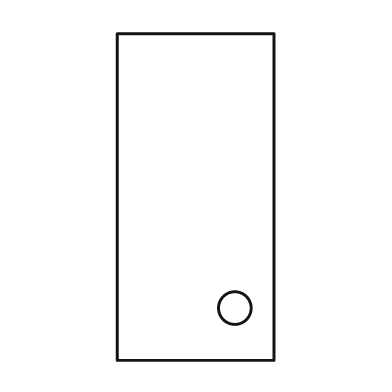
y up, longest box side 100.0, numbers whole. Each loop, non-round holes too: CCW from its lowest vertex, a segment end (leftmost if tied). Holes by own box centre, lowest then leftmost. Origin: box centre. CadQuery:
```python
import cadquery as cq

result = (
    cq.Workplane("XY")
    .moveTo(-24.0, -50.0)
    .lineTo(24.0, -50.0)
    .lineTo(24.0, 50.0)
    .lineTo(-24.0, 50.0)
    .close()
    .moveTo(12.0, -34.0)
    .circle(5.0)
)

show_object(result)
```